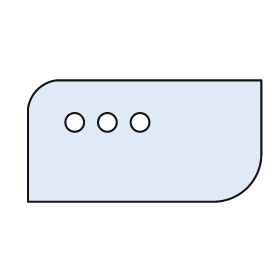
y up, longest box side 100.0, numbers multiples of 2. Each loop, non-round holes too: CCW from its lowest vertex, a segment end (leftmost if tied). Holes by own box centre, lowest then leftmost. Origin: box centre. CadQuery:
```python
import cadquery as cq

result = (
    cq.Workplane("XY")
    .moveTo(-50.0, -26.0)
    .lineTo(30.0, -26.0)
    .threePointArc((44.0, -20.0), (50.0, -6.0))
    .lineTo(50.0, 26.0)
    .lineTo(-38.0, 26.0)
    .threePointArc((-46.0, 22.0), (-50.0, 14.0))
    .close()
    .moveTo(-30.0, 8.0)
    .circle(4.0)
    .moveTo(-16.0, 8.0)
    .circle(4.0)
    .moveTo(-2.0, 8.0)
    .circle(4.0)
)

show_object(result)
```